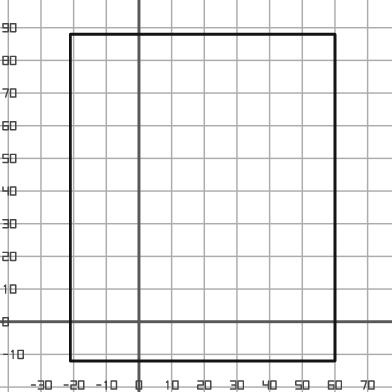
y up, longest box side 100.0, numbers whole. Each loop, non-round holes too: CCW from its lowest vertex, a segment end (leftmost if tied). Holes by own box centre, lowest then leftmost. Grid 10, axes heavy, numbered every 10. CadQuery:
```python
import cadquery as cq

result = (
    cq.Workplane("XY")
    .moveTo(-21.0, -12.0)
    .lineTo(60.0, -12.0)
    .lineTo(60.0, 88.0)
    .lineTo(-21.0, 88.0)
    .close()
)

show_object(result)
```